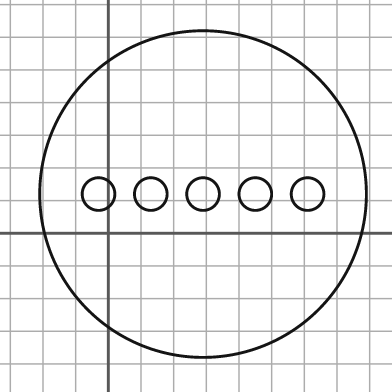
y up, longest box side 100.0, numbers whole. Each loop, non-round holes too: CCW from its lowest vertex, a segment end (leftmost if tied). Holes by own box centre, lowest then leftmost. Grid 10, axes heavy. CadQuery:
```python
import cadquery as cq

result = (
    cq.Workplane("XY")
    .moveTo(29.0, 12.0)
    .circle(50.0)
    .moveTo(-3.0, 12.0)
    .circle(5.0)
    .moveTo(13.0, 12.0)
    .circle(5.0)
    .moveTo(29.0, 12.0)
    .circle(5.0)
    .moveTo(45.0, 12.0)
    .circle(5.0)
    .moveTo(61.0, 12.0)
    .circle(5.0)
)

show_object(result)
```